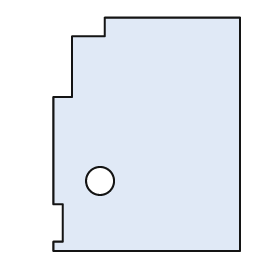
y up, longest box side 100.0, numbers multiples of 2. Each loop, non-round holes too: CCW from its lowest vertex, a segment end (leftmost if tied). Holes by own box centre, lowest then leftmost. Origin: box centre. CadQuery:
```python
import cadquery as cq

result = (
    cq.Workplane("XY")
    .moveTo(-40.0, -50.0)
    .lineTo(40.0, -50.0)
    .lineTo(40.0, 50.0)
    .lineTo(-18.0, 50.0)
    .lineTo(-18.0, 42.0)
    .lineTo(-32.0, 42.0)
    .lineTo(-32.0, 16.0)
    .lineTo(-40.0, 16.0)
    .lineTo(-40.0, -30.0)
    .lineTo(-36.0, -30.0)
    .lineTo(-36.0, -46.0)
    .lineTo(-40.0, -46.0)
    .close()
    .moveTo(-20.0, -20.0)
    .circle(6.0)
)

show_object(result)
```